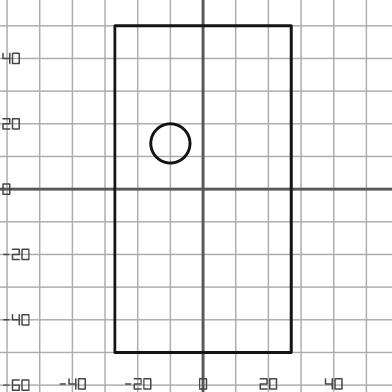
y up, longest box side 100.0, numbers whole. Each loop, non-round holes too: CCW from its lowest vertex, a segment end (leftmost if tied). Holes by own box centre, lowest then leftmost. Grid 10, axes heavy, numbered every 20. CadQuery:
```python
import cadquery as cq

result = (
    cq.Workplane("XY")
    .moveTo(-27.0, -50.0)
    .lineTo(27.0, -50.0)
    .lineTo(27.0, 50.0)
    .lineTo(-27.0, 50.0)
    .close()
    .moveTo(-10.0, 14.0)
    .circle(6.0)
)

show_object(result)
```